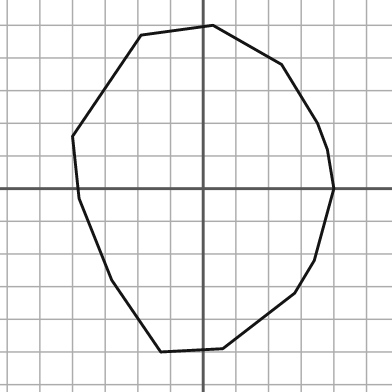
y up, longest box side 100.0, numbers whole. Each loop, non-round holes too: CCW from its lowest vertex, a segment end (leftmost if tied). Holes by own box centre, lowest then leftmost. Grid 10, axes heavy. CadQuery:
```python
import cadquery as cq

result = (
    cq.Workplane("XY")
    .moveTo(-13.0, -50.0)
    .lineTo(6.0, -49.0)
    .lineTo(28.0, -32.0)
    .lineTo(34.0, -22.0)
    .lineTo(40.0, 0.0)
    .lineTo(38.0, 12.0)
    .lineTo(35.0, 20.0)
    .lineTo(24.0, 38.0)
    .lineTo(3.0, 50.0)
    .lineTo(-19.0, 47.0)
    .lineTo(-40.0, 16.0)
    .lineTo(-38.0, -3.0)
    .lineTo(-28.0, -28.0)
    .close()
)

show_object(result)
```